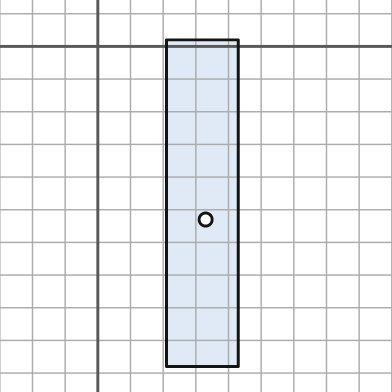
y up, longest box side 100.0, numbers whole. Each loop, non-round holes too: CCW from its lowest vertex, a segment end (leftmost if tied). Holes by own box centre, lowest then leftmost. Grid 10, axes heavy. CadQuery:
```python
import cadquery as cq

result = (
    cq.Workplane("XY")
    .moveTo(21.0, -98.0)
    .lineTo(43.0, -98.0)
    .lineTo(43.0, 2.0)
    .lineTo(21.0, 2.0)
    .close()
    .moveTo(33.0, -53.0)
    .circle(2.0)
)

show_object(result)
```